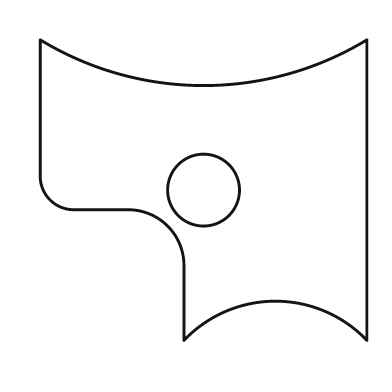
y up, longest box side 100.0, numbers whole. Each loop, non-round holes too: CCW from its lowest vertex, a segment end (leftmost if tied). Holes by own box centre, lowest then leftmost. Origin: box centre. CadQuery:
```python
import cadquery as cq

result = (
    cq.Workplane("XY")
    .moveTo(-6.0, -46.0)
    .threePointArc((22.0, -34.0), (50.0, -46.0))
    .lineTo(50.0, 46.0)
    .threePointArc((0.0, 32.0), (-50.0, 46.0))
    .lineTo(-50.0, 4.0)
    .threePointArc((-47.0, -3.0), (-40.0, -6.0))
    .lineTo(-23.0, -6.0)
    .threePointArc((-11.0, -11.0), (-6.0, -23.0))
    .close()
    .moveTo(0.0, 0.0)
    .circle(11.0)
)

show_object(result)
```